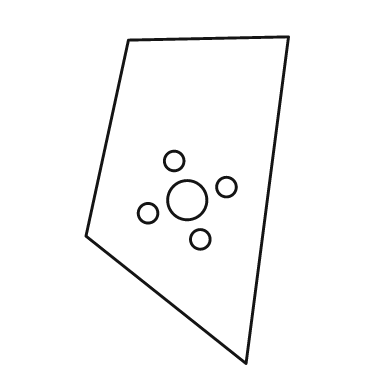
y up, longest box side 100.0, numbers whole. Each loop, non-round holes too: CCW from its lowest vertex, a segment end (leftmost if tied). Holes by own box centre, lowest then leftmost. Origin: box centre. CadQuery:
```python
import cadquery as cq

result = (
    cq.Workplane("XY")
    .moveTo(18.0, -50.0)
    .lineTo(31.0, 50.0)
    .lineTo(-18.0, 49.0)
    .lineTo(-31.0, -11.0)
    .close()
    .moveTo(4.0, -12.0)
    .circle(3.0)
    .moveTo(-12.0, -4.0)
    .circle(3.0)
    .moveTo(0.0, 0.0)
    .circle(6.0)
    .moveTo(12.0, 4.0)
    .circle(3.0)
    .moveTo(-4.0, 12.0)
    .circle(3.0)
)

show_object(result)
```